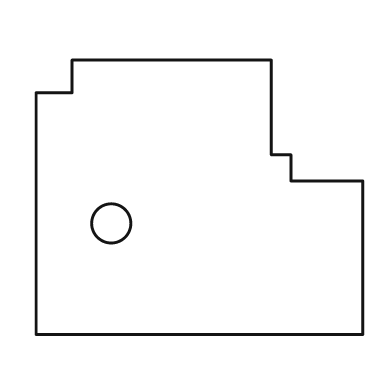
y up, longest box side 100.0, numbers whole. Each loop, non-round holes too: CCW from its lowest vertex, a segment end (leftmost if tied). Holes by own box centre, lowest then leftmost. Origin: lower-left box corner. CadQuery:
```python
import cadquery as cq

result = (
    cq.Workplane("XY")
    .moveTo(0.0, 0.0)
    .lineTo(100.0, 0.0)
    .lineTo(100.0, 47.0)
    .lineTo(78.0, 47.0)
    .lineTo(78.0, 55.0)
    .lineTo(72.0, 55.0)
    .lineTo(72.0, 84.0)
    .lineTo(11.0, 84.0)
    .lineTo(11.0, 74.0)
    .lineTo(0.0, 74.0)
    .close()
    .moveTo(23.0, 34.0)
    .circle(6.0)
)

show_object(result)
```